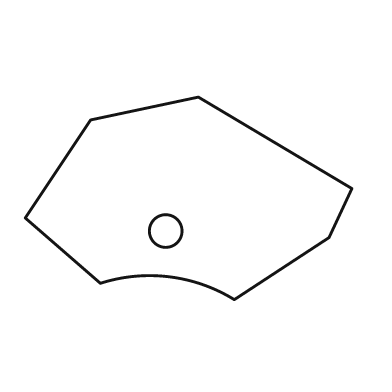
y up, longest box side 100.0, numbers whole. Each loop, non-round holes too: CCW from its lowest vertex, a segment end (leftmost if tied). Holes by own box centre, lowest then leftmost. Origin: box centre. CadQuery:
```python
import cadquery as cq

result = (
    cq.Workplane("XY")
    .moveTo(14.0, -31.0)
    .lineTo(43.0, -12.0)
    .lineTo(50.0, 3.0)
    .lineTo(3.0, 31.0)
    .lineTo(-30.0, 24.0)
    .lineTo(-50.0, -6.0)
    .lineTo(-27.0, -26.0)
    .threePointArc((-6.0, -24.0), (14.0, -31.0))
    .close()
    .moveTo(-7.0, -10.0)
    .circle(5.0)
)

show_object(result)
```